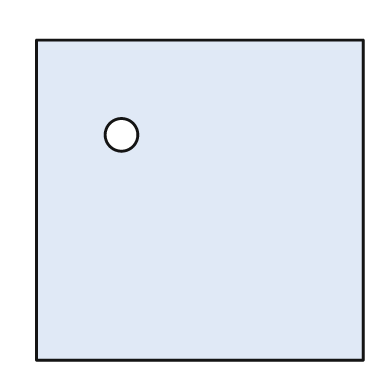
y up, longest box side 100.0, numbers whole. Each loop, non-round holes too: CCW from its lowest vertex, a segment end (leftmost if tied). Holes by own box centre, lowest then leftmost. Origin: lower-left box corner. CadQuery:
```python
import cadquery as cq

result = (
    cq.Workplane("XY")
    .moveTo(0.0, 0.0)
    .lineTo(100.0, 0.0)
    .lineTo(100.0, 98.0)
    .lineTo(0.0, 98.0)
    .close()
    .moveTo(26.0, 69.0)
    .circle(5.0)
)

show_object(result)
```